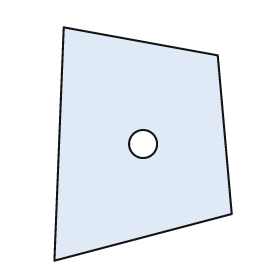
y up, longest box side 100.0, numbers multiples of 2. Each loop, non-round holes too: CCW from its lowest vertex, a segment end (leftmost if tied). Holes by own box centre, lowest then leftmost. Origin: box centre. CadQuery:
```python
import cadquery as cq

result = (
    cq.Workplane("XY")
    .moveTo(-38.0, -50.0)
    .lineTo(38.0, -30.0)
    .lineTo(32.0, 38.0)
    .lineTo(-34.0, 50.0)
    .close()
    .moveTo(0.0, 0.0)
    .circle(6.0)
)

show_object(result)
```